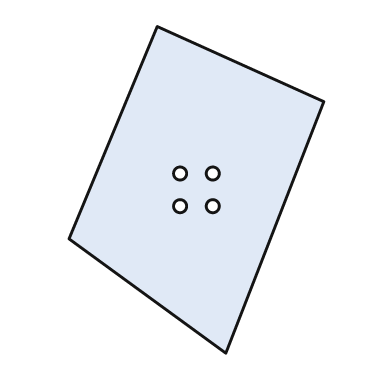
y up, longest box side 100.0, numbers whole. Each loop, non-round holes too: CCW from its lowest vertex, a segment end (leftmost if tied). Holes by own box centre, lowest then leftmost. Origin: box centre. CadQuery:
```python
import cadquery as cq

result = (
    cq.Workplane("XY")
    .moveTo(9.0, -50.0)
    .lineTo(39.0, 27.0)
    .lineTo(-12.0, 50.0)
    .lineTo(-39.0, -15.0)
    .close()
    .moveTo(-5.0, -5.0)
    .circle(2.0)
    .moveTo(5.0, -5.0)
    .circle(2.0)
    .moveTo(-5.0, 5.0)
    .circle(2.0)
    .moveTo(5.0, 5.0)
    .circle(2.0)
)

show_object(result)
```